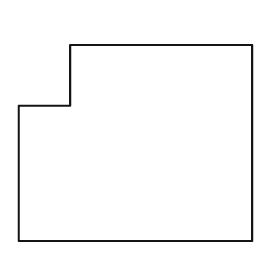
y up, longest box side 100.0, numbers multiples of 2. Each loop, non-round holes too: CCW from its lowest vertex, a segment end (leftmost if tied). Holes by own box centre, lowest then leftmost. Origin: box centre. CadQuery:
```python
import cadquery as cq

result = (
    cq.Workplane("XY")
    .moveTo(-50.0, -42.0)
    .lineTo(50.0, -42.0)
    .lineTo(50.0, 42.0)
    .lineTo(-28.0, 42.0)
    .lineTo(-28.0, 16.0)
    .lineTo(-50.0, 16.0)
    .close()
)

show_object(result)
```